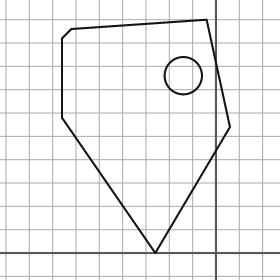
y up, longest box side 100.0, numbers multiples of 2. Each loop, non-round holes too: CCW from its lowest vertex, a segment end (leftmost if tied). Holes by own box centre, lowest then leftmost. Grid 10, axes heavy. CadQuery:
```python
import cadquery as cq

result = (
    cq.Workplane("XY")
    .moveTo(-26.0, 0.0)
    .lineTo(6.0, 54.0)
    .lineTo(-4.0, 100.0)
    .lineTo(-62.0, 96.0)
    .lineTo(-66.0, 92.0)
    .lineTo(-66.0, 58.0)
    .close()
    .moveTo(-14.0, 76.0)
    .circle(8.0)
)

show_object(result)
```